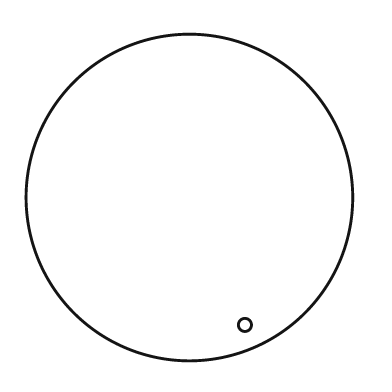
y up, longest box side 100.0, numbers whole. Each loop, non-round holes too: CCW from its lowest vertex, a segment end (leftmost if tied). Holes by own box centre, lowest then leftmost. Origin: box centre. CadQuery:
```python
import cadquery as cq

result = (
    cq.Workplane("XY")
    .moveTo(0.0, 0.0)
    .circle(50.0)
    .moveTo(17.0, -39.0)
    .circle(2.0)
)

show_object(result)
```